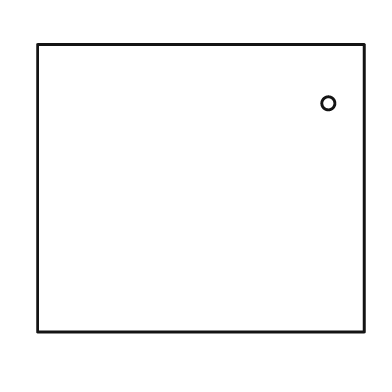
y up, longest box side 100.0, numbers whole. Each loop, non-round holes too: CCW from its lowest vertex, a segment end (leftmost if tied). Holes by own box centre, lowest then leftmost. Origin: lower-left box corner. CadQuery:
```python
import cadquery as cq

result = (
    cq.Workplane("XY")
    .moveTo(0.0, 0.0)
    .lineTo(100.0, 0.0)
    .lineTo(100.0, 88.0)
    .lineTo(0.0, 88.0)
    .close()
    .moveTo(89.0, 70.0)
    .circle(2.0)
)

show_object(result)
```